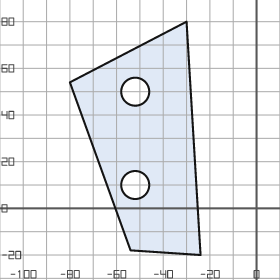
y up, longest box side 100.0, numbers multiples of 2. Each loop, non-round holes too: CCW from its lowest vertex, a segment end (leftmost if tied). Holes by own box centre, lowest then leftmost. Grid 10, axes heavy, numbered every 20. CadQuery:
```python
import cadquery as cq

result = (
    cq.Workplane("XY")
    .moveTo(-24.0, -20.0)
    .lineTo(-30.0, 80.0)
    .lineTo(-80.0, 54.0)
    .lineTo(-54.0, -18.0)
    .close()
    .moveTo(-52.0, 10.0)
    .circle(6.0)
    .moveTo(-52.0, 50.0)
    .circle(6.0)
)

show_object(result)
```